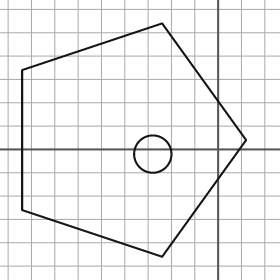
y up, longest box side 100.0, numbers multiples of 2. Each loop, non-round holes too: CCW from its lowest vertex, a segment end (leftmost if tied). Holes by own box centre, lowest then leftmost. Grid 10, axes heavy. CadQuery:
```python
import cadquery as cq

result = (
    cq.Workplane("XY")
    .moveTo(-24.0, -46.0)
    .lineTo(12.0, 4.0)
    .lineTo(-24.0, 54.0)
    .lineTo(-84.0, 34.0)
    .lineTo(-84.0, -26.0)
    .close()
    .moveTo(-28.0, -2.0)
    .circle(8.0)
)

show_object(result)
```